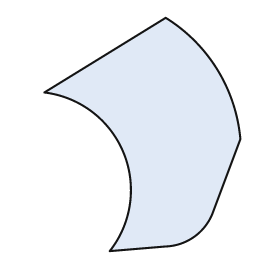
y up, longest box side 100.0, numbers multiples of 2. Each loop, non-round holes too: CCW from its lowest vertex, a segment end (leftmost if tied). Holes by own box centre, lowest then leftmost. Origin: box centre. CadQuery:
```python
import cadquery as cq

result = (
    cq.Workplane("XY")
    .moveTo(-14.0, -50.0)
    .lineTo(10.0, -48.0)
    .threePointArc((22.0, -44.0), (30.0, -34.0))
    .lineTo(42.0, -2.0)
    .threePointArc((32.0, 28.0), (10.0, 50.0))
    .lineTo(-42.0, 18.0)
    .threePointArc((-8.0, -8.0), (-14.0, -50.0))
    .close()
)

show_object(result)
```